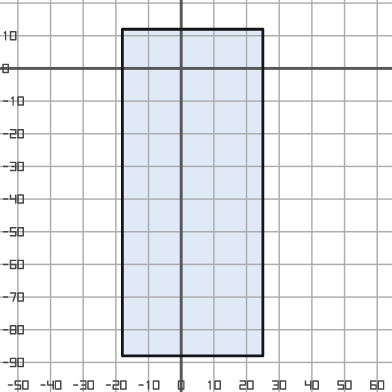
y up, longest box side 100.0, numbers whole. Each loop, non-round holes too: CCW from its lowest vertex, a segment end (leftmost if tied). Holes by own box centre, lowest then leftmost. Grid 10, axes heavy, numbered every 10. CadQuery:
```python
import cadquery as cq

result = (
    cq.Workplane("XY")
    .moveTo(-18.0, -88.0)
    .lineTo(25.0, -88.0)
    .lineTo(25.0, 12.0)
    .lineTo(-18.0, 12.0)
    .close()
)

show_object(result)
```